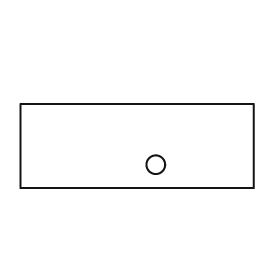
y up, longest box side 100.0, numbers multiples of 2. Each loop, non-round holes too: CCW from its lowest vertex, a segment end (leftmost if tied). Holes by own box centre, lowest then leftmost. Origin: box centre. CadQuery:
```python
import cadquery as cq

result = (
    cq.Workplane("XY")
    .moveTo(-50.0, -18.0)
    .lineTo(50.0, -18.0)
    .lineTo(50.0, 18.0)
    .lineTo(-50.0, 18.0)
    .close()
    .moveTo(8.0, -8.0)
    .circle(4.0)
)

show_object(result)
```